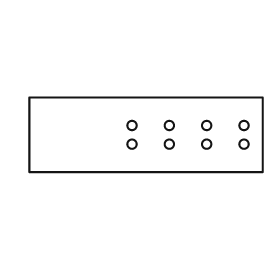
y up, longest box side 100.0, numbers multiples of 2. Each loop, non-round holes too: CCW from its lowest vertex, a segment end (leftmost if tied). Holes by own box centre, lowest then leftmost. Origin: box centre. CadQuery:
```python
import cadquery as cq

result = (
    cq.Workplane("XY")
    .moveTo(-50.0, -16.0)
    .lineTo(50.0, -16.0)
    .lineTo(50.0, 16.0)
    .lineTo(-50.0, 16.0)
    .close()
    .moveTo(-6.0, -4.0)
    .circle(2.0)
    .moveTo(10.0, -4.0)
    .circle(2.0)
    .moveTo(26.0, -4.0)
    .circle(2.0)
    .moveTo(42.0, -4.0)
    .circle(2.0)
    .moveTo(-6.0, 4.0)
    .circle(2.0)
    .moveTo(10.0, 4.0)
    .circle(2.0)
    .moveTo(26.0, 4.0)
    .circle(2.0)
    .moveTo(42.0, 4.0)
    .circle(2.0)
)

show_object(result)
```